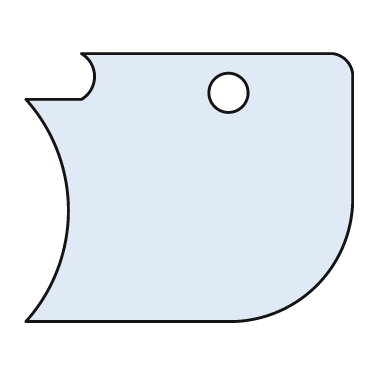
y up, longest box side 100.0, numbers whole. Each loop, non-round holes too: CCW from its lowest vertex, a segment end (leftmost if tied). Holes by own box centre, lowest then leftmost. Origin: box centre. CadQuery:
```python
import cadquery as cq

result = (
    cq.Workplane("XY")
    .moveTo(-50.0, -41.0)
    .lineTo(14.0, -41.0)
    .threePointArc((39.0, -30.0), (50.0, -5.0))
    .lineTo(50.0, 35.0)
    .threePointArc((48.0, 39.0), (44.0, 41.0))
    .lineTo(-33.0, 41.0)
    .threePointArc((-29.0, 34.0), (-33.0, 27.0))
    .lineTo(-50.0, 27.0)
    .threePointArc((-37.0, -7.0), (-50.0, -41.0))
    .close()
    .moveTo(12.0, 29.0)
    .circle(6.0)
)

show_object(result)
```